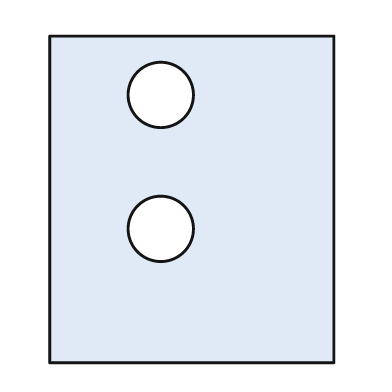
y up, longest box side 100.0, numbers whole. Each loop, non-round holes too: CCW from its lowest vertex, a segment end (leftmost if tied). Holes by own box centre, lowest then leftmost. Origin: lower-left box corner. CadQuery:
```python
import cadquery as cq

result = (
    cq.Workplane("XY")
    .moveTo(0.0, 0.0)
    .lineTo(87.0, 0.0)
    .lineTo(87.0, 100.0)
    .lineTo(0.0, 100.0)
    .close()
    .moveTo(34.0, 41.0)
    .circle(10.0)
    .moveTo(34.0, 82.0)
    .circle(10.0)
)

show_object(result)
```